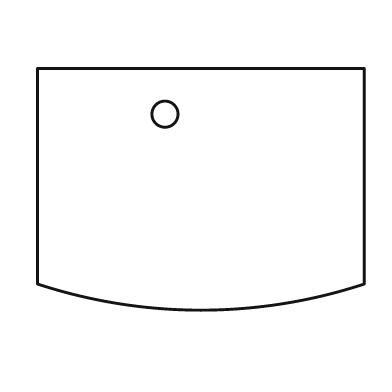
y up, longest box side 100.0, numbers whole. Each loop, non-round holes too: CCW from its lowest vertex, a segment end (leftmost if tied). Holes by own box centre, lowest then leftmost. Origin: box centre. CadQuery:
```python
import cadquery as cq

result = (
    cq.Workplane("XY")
    .moveTo(-50.0, -29.0)
    .threePointArc((0.0, -37.0), (50.0, -29.0))
    .lineTo(50.0, 37.0)
    .lineTo(-50.0, 37.0)
    .close()
    .moveTo(-11.0, 23.0)
    .circle(4.0)
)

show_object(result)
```